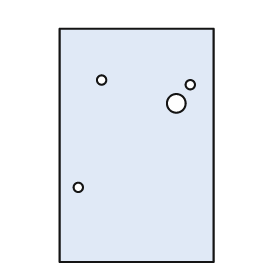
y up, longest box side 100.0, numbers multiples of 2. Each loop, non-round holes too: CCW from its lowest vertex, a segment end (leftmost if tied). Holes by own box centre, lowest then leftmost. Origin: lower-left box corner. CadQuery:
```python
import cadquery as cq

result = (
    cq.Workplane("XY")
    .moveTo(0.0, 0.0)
    .lineTo(66.0, 0.0)
    .lineTo(66.0, 100.0)
    .lineTo(0.0, 100.0)
    .close()
    .moveTo(8.0, 32.0)
    .circle(2.0)
    .moveTo(50.0, 68.0)
    .circle(4.0)
    .moveTo(56.0, 76.0)
    .circle(2.0)
    .moveTo(18.0, 78.0)
    .circle(2.0)
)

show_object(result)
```